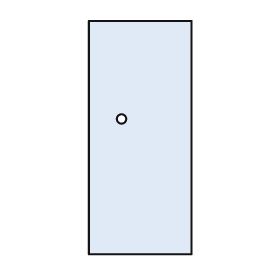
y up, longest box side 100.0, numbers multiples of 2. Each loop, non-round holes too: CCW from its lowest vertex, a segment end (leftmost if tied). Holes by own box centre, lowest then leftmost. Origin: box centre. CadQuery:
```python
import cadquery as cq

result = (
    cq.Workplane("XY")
    .moveTo(-22.0, -50.0)
    .lineTo(22.0, -50.0)
    .lineTo(22.0, 50.0)
    .lineTo(-22.0, 50.0)
    .close()
    .moveTo(-8.0, 8.0)
    .circle(2.0)
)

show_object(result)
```